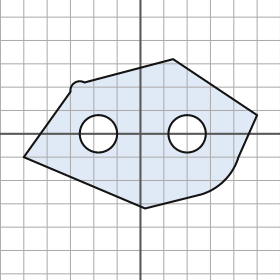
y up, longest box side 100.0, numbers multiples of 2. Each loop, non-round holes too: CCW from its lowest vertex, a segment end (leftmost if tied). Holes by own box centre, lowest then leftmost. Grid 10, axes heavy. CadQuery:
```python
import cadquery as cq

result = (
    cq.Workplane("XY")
    .moveTo(2.0, -32.0)
    .lineTo(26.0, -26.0)
    .threePointArc((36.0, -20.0), (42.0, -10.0))
    .lineTo(50.0, 8.0)
    .lineTo(14.0, 32.0)
    .lineTo(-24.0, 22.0)
    .threePointArc((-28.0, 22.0), (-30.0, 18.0))
    .lineTo(-50.0, -10.0)
    .close()
    .moveTo(-18.0, 0.0)
    .circle(8.0)
    .moveTo(20.0, 0.0)
    .circle(8.0)
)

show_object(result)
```